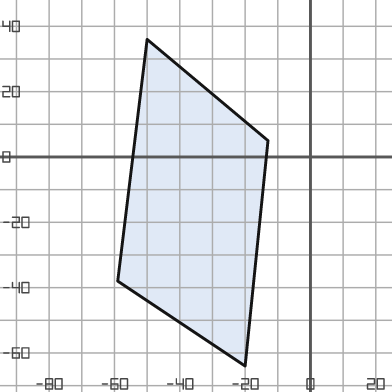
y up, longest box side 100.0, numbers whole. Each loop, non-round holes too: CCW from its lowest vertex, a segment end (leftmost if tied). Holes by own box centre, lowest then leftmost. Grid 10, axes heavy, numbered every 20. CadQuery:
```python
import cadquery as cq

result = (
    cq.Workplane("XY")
    .moveTo(-20.0, -64.0)
    .lineTo(-13.0, 5.0)
    .lineTo(-50.0, 36.0)
    .lineTo(-59.0, -38.0)
    .close()
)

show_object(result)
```